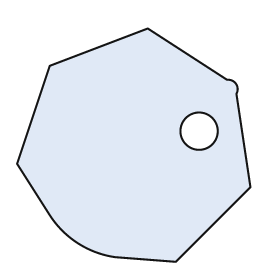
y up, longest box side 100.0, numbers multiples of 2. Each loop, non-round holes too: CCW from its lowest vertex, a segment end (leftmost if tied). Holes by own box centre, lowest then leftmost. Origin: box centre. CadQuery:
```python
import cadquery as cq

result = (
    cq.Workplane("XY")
    .moveTo(18.0, -50.0)
    .lineTo(50.0, -18.0)
    .lineTo(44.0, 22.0)
    .threePointArc((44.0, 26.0), (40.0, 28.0))
    .lineTo(6.0, 50.0)
    .lineTo(-36.0, 34.0)
    .lineTo(-50.0, -8.0)
    .lineTo(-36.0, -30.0)
    .threePointArc((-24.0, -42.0), (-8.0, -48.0))
    .close()
    .moveTo(28.0, 6.0)
    .circle(8.0)
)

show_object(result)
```